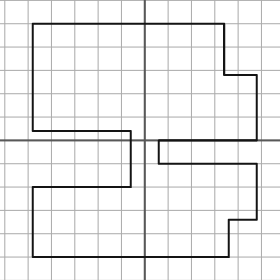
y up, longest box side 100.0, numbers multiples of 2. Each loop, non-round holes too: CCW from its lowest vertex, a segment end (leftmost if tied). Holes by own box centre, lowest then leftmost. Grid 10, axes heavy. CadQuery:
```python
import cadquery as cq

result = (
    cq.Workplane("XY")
    .moveTo(-48.0, -50.0)
    .lineTo(36.0, -50.0)
    .lineTo(36.0, -34.0)
    .lineTo(48.0, -34.0)
    .lineTo(48.0, -10.0)
    .lineTo(6.0, -10.0)
    .lineTo(6.0, 0.0)
    .lineTo(48.0, 0.0)
    .lineTo(48.0, 28.0)
    .lineTo(34.0, 28.0)
    .lineTo(34.0, 50.0)
    .lineTo(-48.0, 50.0)
    .lineTo(-48.0, 4.0)
    .lineTo(-6.0, 4.0)
    .lineTo(-6.0, -20.0)
    .lineTo(-48.0, -20.0)
    .close()
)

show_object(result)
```